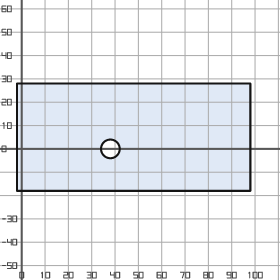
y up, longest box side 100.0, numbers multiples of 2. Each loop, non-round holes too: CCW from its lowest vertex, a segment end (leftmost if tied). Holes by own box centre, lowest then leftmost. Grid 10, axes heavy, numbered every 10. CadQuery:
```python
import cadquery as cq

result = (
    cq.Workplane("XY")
    .moveTo(-2.0, -18.0)
    .lineTo(98.0, -18.0)
    .lineTo(98.0, 28.0)
    .lineTo(-2.0, 28.0)
    .close()
    .moveTo(38.0, 0.0)
    .circle(4.0)
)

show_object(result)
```